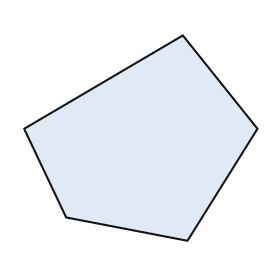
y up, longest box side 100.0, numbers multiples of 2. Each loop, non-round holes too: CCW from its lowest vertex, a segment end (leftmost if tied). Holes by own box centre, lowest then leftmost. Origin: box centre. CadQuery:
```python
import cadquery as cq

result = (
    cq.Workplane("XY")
    .moveTo(20.0, -44.0)
    .lineTo(50.0, 4.0)
    .lineTo(18.0, 44.0)
    .lineTo(-50.0, 4.0)
    .lineTo(-32.0, -34.0)
    .close()
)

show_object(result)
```